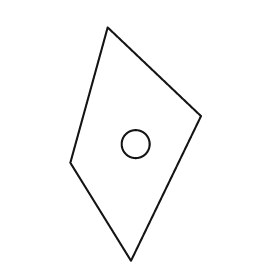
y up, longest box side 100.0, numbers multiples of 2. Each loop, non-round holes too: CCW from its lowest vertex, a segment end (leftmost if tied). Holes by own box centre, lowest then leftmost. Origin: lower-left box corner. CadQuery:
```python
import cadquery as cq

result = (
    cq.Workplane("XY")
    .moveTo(26.0, 0.0)
    .lineTo(56.0, 62.0)
    .lineTo(16.0, 100.0)
    .lineTo(0.0, 42.0)
    .close()
    .moveTo(28.0, 50.0)
    .circle(6.0)
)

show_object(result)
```